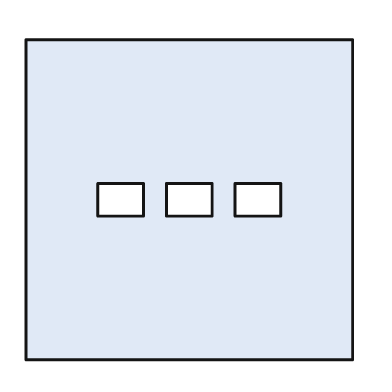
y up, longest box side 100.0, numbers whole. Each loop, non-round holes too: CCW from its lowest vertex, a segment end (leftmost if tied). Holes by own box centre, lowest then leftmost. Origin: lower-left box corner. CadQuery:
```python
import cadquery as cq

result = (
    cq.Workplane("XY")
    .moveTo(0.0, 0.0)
    .lineTo(100.0, 0.0)
    .lineTo(100.0, 98.0)
    .lineTo(0.0, 98.0)
    .close()
    .moveTo(22.0, 44.0)
    .lineTo(36.0, 44.0)
    .lineTo(36.0, 54.0)
    .lineTo(22.0, 54.0)
    .close()
    .moveTo(43.0, 44.0)
    .lineTo(57.0, 44.0)
    .lineTo(57.0, 54.0)
    .lineTo(43.0, 54.0)
    .close()
    .moveTo(64.0, 44.0)
    .lineTo(78.0, 44.0)
    .lineTo(78.0, 54.0)
    .lineTo(64.0, 54.0)
    .close()
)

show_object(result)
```